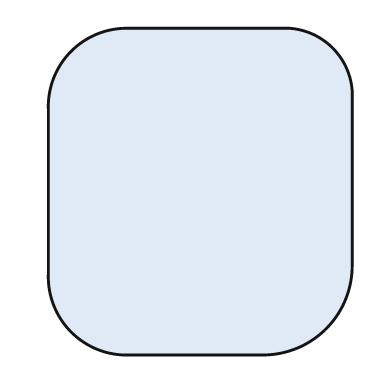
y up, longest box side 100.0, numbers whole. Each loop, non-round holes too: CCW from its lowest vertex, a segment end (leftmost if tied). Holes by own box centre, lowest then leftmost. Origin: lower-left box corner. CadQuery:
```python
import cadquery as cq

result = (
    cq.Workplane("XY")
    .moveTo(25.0, 0.0)
    .lineTo(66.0, 0.0)
    .threePointArc((85.0, 8.0), (93.0, 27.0))
    .lineTo(93.0, 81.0)
    .threePointArc((87.0, 94.0), (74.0, 100.0))
    .lineTo(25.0, 100.0)
    .threePointArc((7.0, 93.0), (0.0, 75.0))
    .lineTo(0.0, 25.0)
    .threePointArc((7.0, 7.0), (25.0, 0.0))
    .close()
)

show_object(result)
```